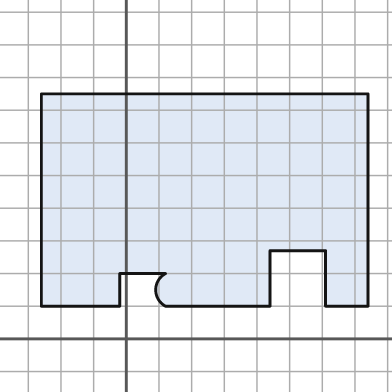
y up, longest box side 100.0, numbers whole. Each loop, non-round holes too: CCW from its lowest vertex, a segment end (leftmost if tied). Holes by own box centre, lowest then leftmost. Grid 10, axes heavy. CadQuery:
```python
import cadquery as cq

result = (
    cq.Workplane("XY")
    .moveTo(-26.0, 10.0)
    .lineTo(-2.0, 10.0)
    .lineTo(-2.0, 20.0)
    .lineTo(12.0, 20.0)
    .threePointArc((9.0, 15.0), (12.0, 10.0))
    .lineTo(44.0, 10.0)
    .lineTo(44.0, 27.0)
    .lineTo(61.0, 27.0)
    .lineTo(61.0, 10.0)
    .lineTo(74.0, 10.0)
    .lineTo(74.0, 75.0)
    .lineTo(-26.0, 75.0)
    .close()
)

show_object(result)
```